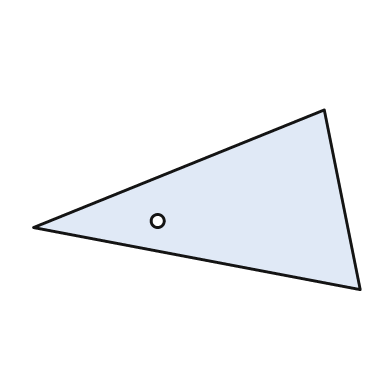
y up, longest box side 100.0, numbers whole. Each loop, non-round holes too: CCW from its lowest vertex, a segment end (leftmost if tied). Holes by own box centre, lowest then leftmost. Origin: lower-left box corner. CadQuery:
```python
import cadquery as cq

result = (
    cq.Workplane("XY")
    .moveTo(100.0, 0.0)
    .lineTo(89.0, 55.0)
    .lineTo(0.0, 19.0)
    .close()
    .moveTo(38.0, 21.0)
    .circle(2.0)
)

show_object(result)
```